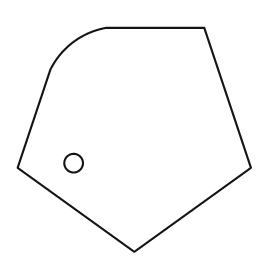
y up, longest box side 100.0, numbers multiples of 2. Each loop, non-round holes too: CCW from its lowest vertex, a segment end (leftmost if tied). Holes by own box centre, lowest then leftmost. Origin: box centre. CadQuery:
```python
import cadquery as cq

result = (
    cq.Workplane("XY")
    .moveTo(0.0, -48.0)
    .lineTo(50.0, -12.0)
    .lineTo(30.0, 48.0)
    .lineTo(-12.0, 48.0)
    .threePointArc((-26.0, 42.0), (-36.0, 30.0))
    .lineTo(-50.0, -12.0)
    .close()
    .moveTo(-26.0, -10.0)
    .circle(4.0)
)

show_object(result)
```